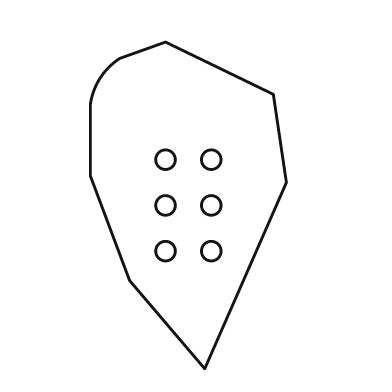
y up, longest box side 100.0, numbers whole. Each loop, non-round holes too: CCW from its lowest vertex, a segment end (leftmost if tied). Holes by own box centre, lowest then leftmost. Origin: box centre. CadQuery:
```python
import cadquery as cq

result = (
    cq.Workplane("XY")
    .moveTo(5.0, -50.0)
    .lineTo(30.0, 7.0)
    .lineTo(26.0, 34.0)
    .lineTo(-7.0, 50.0)
    .lineTo(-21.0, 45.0)
    .threePointArc((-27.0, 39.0), (-30.0, 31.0))
    .lineTo(-30.0, 9.0)
    .lineTo(-18.0, -23.0)
    .close()
    .moveTo(-7.0, -14.0)
    .circle(3.0)
    .moveTo(7.0, -14.0)
    .circle(3.0)
    .moveTo(-7.0, 0.0)
    .circle(3.0)
    .moveTo(7.0, 0.0)
    .circle(3.0)
    .moveTo(-7.0, 14.0)
    .circle(3.0)
    .moveTo(7.0, 14.0)
    .circle(3.0)
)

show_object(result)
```